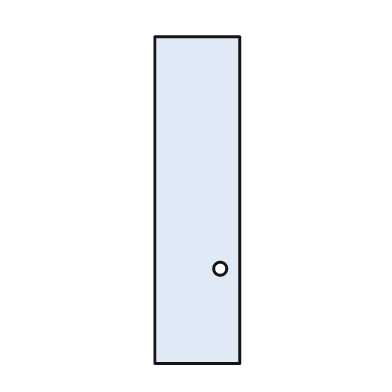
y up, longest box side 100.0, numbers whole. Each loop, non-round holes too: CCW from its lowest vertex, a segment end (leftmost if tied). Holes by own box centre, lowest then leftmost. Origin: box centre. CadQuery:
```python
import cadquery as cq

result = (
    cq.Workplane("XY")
    .moveTo(-13.0, -50.0)
    .lineTo(13.0, -50.0)
    .lineTo(13.0, 50.0)
    .lineTo(-13.0, 50.0)
    .close()
    .moveTo(7.0, -21.0)
    .circle(2.0)
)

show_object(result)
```